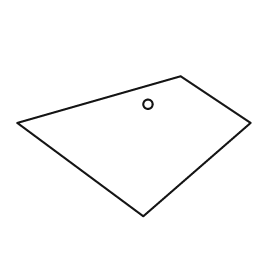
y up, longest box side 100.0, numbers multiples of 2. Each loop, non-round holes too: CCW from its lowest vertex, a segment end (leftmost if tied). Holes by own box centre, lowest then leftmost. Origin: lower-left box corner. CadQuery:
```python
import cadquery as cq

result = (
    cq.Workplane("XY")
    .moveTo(54.0, 0.0)
    .lineTo(100.0, 40.0)
    .lineTo(70.0, 60.0)
    .lineTo(0.0, 40.0)
    .close()
    .moveTo(56.0, 48.0)
    .circle(2.0)
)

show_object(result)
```